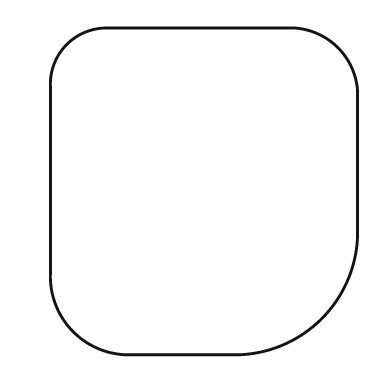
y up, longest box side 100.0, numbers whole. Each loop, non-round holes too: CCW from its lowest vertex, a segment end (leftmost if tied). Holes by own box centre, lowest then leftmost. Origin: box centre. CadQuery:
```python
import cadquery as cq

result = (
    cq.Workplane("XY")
    .moveTo(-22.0, -50.0)
    .lineTo(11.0, -50.0)
    .threePointArc((36.0, -39.0), (47.0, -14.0))
    .lineTo(47.0, 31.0)
    .threePointArc((41.0, 44.0), (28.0, 50.0))
    .lineTo(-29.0, 50.0)
    .threePointArc((-42.0, 45.0), (-47.0, 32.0))
    .lineTo(-47.0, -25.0)
    .threePointArc((-40.0, -43.0), (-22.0, -50.0))
    .close()
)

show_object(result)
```